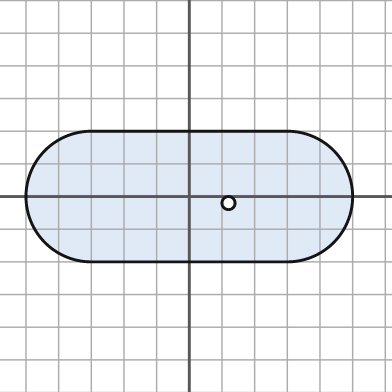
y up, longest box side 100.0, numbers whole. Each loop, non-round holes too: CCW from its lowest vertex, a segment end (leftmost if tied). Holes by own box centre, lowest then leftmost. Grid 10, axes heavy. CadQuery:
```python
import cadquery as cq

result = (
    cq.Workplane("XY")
    .moveTo(-30.0, -20.0)
    .lineTo(30.0, -20.0)
    .threePointArc((50.0, 0.0), (30.0, 20.0))
    .lineTo(-30.0, 20.0)
    .threePointArc((-50.0, 0.0), (-30.0, -20.0))
    .close()
    .moveTo(12.0, -2.0)
    .circle(2.0)
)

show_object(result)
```